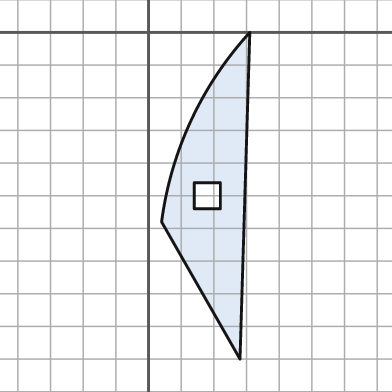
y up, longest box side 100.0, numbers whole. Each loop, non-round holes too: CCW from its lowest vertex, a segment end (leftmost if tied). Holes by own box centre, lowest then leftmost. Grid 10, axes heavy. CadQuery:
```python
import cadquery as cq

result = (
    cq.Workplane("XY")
    .moveTo(28.0, -100.0)
    .lineTo(31.0, 0.0)
    .threePointArc((13.0, -27.0), (4.0, -58.0))
    .close()
    .moveTo(14.0, -54.0)
    .lineTo(22.0, -54.0)
    .lineTo(22.0, -46.0)
    .lineTo(14.0, -46.0)
    .close()
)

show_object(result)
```